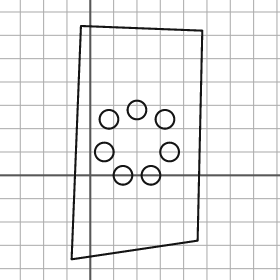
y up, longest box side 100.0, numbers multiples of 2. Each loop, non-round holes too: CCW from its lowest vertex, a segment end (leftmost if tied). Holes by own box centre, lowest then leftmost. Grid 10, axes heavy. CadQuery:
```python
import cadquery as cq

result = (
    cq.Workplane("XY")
    .moveTo(-8.0, -36.0)
    .lineTo(46.0, -28.0)
    .lineTo(48.0, 62.0)
    .lineTo(-4.0, 64.0)
    .close()
    .moveTo(14.0, 0.0)
    .circle(4.0)
    .moveTo(26.0, 0.0)
    .circle(4.0)
    .moveTo(6.0, 10.0)
    .circle(4.0)
    .moveTo(34.0, 10.0)
    .circle(4.0)
    .moveTo(8.0, 24.0)
    .circle(4.0)
    .moveTo(32.0, 24.0)
    .circle(4.0)
    .moveTo(20.0, 28.0)
    .circle(4.0)
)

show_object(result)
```